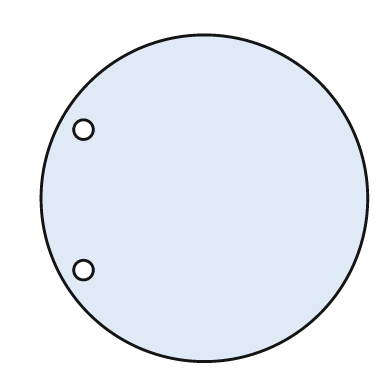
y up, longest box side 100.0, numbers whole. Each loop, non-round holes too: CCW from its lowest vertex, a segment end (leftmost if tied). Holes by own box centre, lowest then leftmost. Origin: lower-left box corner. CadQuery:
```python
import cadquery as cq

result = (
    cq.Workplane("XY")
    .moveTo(50.0, 50.0)
    .circle(50.0)
    .moveTo(13.0, 28.0)
    .circle(3.0)
    .moveTo(13.0, 71.0)
    .circle(3.0)
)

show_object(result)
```